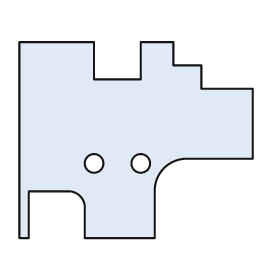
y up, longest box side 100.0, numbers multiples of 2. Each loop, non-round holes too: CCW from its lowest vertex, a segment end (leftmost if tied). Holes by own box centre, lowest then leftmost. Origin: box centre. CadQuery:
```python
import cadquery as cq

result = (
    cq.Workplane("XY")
    .moveTo(-50.0, -42.0)
    .lineTo(-46.0, -42.0)
    .lineTo(-46.0, -22.0)
    .lineTo(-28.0, -22.0)
    .threePointArc((-24.0, -24.0), (-22.0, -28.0))
    .lineTo(-22.0, -42.0)
    .lineTo(8.0, -42.0)
    .lineTo(8.0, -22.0)
    .threePointArc((12.0, -12.0), (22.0, -8.0))
    .lineTo(50.0, -8.0)
    .lineTo(50.0, 22.0)
    .lineTo(28.0, 22.0)
    .lineTo(28.0, 32.0)
    .lineTo(16.0, 32.0)
    .lineTo(16.0, 42.0)
    .lineTo(2.0, 42.0)
    .lineTo(2.0, 26.0)
    .lineTo(-18.0, 26.0)
    .lineTo(-18.0, 42.0)
    .lineTo(-50.0, 42.0)
    .close()
    .moveTo(-18.0, -10.0)
    .circle(4.0)
    .moveTo(2.0, -10.0)
    .circle(4.0)
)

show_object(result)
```